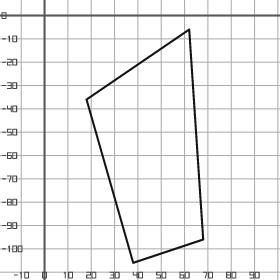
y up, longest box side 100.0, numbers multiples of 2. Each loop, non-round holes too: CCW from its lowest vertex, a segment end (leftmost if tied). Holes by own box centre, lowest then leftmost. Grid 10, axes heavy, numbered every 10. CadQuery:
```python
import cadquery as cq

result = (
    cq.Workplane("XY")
    .moveTo(38.0, -106.0)
    .lineTo(68.0, -96.0)
    .lineTo(62.0, -6.0)
    .lineTo(18.0, -36.0)
    .close()
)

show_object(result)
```